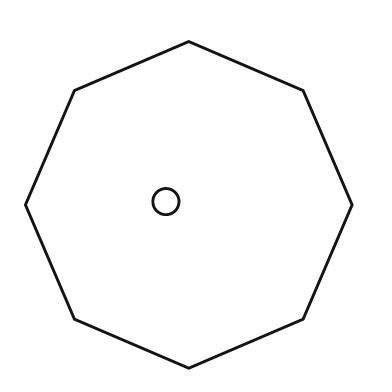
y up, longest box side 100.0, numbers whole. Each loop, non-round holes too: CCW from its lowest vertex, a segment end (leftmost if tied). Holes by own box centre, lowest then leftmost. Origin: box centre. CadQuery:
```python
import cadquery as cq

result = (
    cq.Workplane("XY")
    .moveTo(0.0, -50.0)
    .lineTo(35.0, -35.0)
    .lineTo(50.0, 0.0)
    .lineTo(35.0, 35.0)
    .lineTo(0.0, 50.0)
    .lineTo(-35.0, 35.0)
    .lineTo(-50.0, 0.0)
    .lineTo(-35.0, -35.0)
    .close()
    .moveTo(-7.0, 1.0)
    .circle(4.0)
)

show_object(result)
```